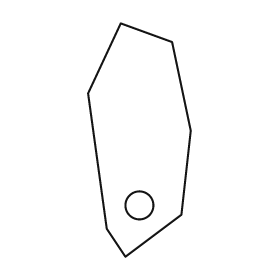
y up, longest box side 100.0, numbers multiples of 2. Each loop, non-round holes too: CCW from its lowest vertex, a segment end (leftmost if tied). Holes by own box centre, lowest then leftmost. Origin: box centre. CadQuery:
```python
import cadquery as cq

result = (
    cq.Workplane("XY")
    .moveTo(-6.0, -50.0)
    .lineTo(18.0, -32.0)
    .lineTo(22.0, 4.0)
    .lineTo(14.0, 42.0)
    .lineTo(-8.0, 50.0)
    .lineTo(-22.0, 20.0)
    .lineTo(-14.0, -38.0)
    .close()
    .moveTo(0.0, -28.0)
    .circle(6.0)
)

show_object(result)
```